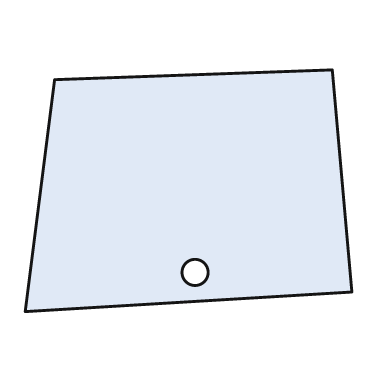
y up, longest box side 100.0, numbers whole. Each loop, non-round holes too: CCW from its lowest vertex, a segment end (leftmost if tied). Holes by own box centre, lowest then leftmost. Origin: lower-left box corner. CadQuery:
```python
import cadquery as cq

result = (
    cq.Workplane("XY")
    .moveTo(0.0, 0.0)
    .lineTo(100.0, 6.0)
    .lineTo(94.0, 74.0)
    .lineTo(9.0, 71.0)
    .close()
    .moveTo(52.0, 12.0)
    .circle(4.0)
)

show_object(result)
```